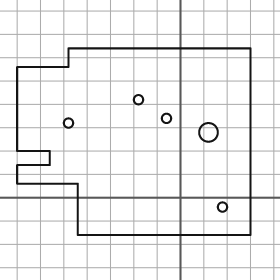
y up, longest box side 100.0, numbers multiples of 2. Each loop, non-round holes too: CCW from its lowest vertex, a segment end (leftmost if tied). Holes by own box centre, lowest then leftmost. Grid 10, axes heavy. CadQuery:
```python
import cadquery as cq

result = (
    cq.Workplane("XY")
    .moveTo(-44.0, -16.0)
    .lineTo(30.0, -16.0)
    .lineTo(30.0, 64.0)
    .lineTo(-48.0, 64.0)
    .lineTo(-48.0, 56.0)
    .lineTo(-70.0, 56.0)
    .lineTo(-70.0, 20.0)
    .lineTo(-56.0, 20.0)
    .lineTo(-56.0, 14.0)
    .lineTo(-70.0, 14.0)
    .lineTo(-70.0, 6.0)
    .lineTo(-44.0, 6.0)
    .close()
    .moveTo(18.0, -4.0)
    .circle(2.0)
    .moveTo(12.0, 28.0)
    .circle(4.0)
    .moveTo(-48.0, 32.0)
    .circle(2.0)
    .moveTo(-6.0, 34.0)
    .circle(2.0)
    .moveTo(-18.0, 42.0)
    .circle(2.0)
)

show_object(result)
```